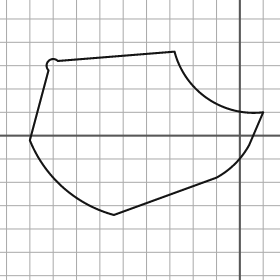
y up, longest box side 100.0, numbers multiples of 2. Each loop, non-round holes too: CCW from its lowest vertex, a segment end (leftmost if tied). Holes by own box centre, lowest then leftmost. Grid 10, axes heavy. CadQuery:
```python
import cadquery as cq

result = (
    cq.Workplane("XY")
    .moveTo(-54.0, -34.0)
    .lineTo(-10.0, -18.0)
    .threePointArc((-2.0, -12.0), (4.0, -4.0))
    .lineTo(10.0, 10.0)
    .threePointArc((-14.0, 16.0), (-28.0, 36.0))
    .lineTo(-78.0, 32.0)
    .threePointArc((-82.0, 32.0), (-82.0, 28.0))
    .lineTo(-90.0, -2.0)
    .threePointArc((-76.0, -22.0), (-54.0, -34.0))
    .close()
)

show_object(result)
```